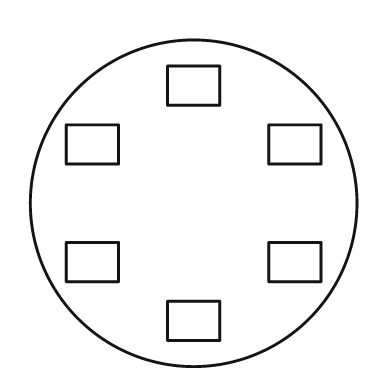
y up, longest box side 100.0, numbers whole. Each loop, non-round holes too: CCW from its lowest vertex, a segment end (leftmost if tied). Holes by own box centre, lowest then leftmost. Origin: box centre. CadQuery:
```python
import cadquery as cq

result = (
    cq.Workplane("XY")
    .moveTo(0.0, 0.0)
    .circle(50.0)
    .moveTo(-8.0, -42.0)
    .lineTo(8.0, -42.0)
    .lineTo(8.0, -30.0)
    .lineTo(-8.0, -30.0)
    .close()
    .moveTo(-39.0, -24.0)
    .lineTo(-23.0, -24.0)
    .lineTo(-23.0, -12.0)
    .lineTo(-39.0, -12.0)
    .close()
    .moveTo(23.0, -24.0)
    .lineTo(39.0, -24.0)
    .lineTo(39.0, -12.0)
    .lineTo(23.0, -12.0)
    .close()
    .moveTo(-39.0, 12.0)
    .lineTo(-23.0, 12.0)
    .lineTo(-23.0, 24.0)
    .lineTo(-39.0, 24.0)
    .close()
    .moveTo(23.0, 12.0)
    .lineTo(39.0, 12.0)
    .lineTo(39.0, 24.0)
    .lineTo(23.0, 24.0)
    .close()
    .moveTo(-8.0, 30.0)
    .lineTo(8.0, 30.0)
    .lineTo(8.0, 42.0)
    .lineTo(-8.0, 42.0)
    .close()
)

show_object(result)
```